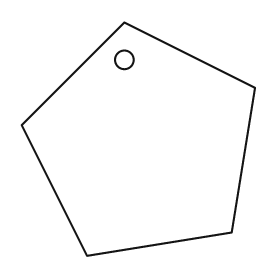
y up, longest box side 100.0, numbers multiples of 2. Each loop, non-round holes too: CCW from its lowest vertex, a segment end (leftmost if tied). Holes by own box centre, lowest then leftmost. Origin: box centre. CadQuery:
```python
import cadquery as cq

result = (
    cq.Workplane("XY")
    .moveTo(-22.0, -50.0)
    .lineTo(40.0, -40.0)
    .lineTo(50.0, 22.0)
    .lineTo(-6.0, 50.0)
    .lineTo(-50.0, 6.0)
    .close()
    .moveTo(-6.0, 34.0)
    .circle(4.0)
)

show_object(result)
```